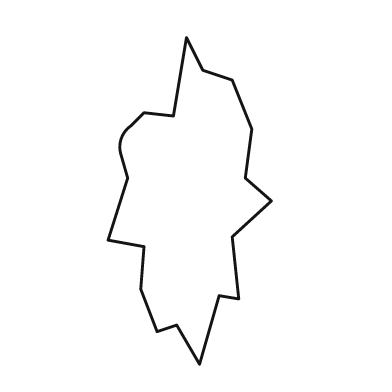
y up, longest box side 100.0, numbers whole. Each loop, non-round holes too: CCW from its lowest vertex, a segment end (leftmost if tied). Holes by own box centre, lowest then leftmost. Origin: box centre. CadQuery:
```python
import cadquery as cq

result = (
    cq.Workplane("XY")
    .moveTo(3.0, -50.0)
    .lineTo(9.0, -29.0)
    .lineTo(15.0, -30.0)
    .lineTo(13.0, -11.0)
    .lineTo(25.0, 0.0)
    .lineTo(17.0, 7.0)
    .lineTo(19.0, 22.0)
    .lineTo(13.0, 37.0)
    .lineTo(4.0, 40.0)
    .lineTo(-1.0, 50.0)
    .lineTo(-5.0, 26.0)
    .lineTo(-14.0, 27.0)
    .lineTo(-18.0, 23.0)
    .threePointArc((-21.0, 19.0), (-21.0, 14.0))
    .lineTo(-19.0, 7.0)
    .lineTo(-25.0, -12.0)
    .lineTo(-14.0, -14.0)
    .lineTo(-15.0, -27.0)
    .lineTo(-10.0, -40.0)
    .lineTo(-4.0, -38.0)
    .close()
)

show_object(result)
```